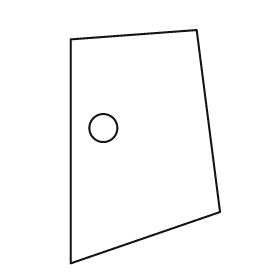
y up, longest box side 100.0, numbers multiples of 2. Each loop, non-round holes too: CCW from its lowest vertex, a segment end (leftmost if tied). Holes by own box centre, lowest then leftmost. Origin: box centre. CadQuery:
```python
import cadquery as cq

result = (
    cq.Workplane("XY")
    .moveTo(-32.0, -50.0)
    .lineTo(32.0, -28.0)
    .lineTo(22.0, 50.0)
    .lineTo(-32.0, 46.0)
    .close()
    .moveTo(-18.0, 8.0)
    .circle(6.0)
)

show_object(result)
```